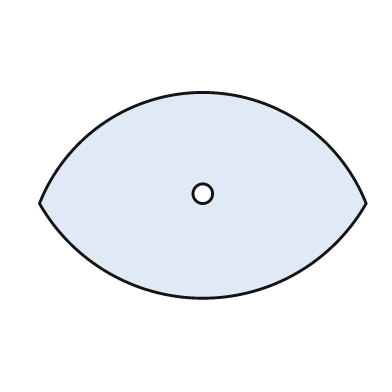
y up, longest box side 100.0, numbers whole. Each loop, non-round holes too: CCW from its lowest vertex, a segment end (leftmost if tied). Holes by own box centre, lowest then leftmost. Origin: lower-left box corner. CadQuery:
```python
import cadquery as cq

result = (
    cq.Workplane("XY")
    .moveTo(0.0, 29.0)
    .threePointArc((50.0, 0.0), (100.0, 29.0))
    .threePointArc((50.0, 63.0), (0.0, 29.0))
    .close()
    .moveTo(50.0, 32.0)
    .circle(3.0)
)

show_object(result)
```